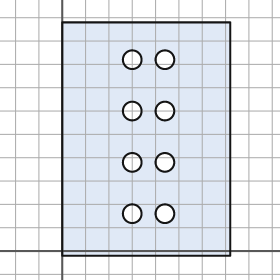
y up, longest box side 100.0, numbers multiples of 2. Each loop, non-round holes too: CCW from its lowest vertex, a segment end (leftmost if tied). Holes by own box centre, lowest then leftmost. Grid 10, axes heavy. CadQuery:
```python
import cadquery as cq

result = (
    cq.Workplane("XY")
    .moveTo(0.0, -2.0)
    .lineTo(72.0, -2.0)
    .lineTo(72.0, 98.0)
    .lineTo(0.0, 98.0)
    .close()
    .moveTo(30.0, 16.0)
    .circle(4.0)
    .moveTo(44.0, 16.0)
    .circle(4.0)
    .moveTo(30.0, 38.0)
    .circle(4.0)
    .moveTo(44.0, 38.0)
    .circle(4.0)
    .moveTo(30.0, 60.0)
    .circle(4.0)
    .moveTo(44.0, 60.0)
    .circle(4.0)
    .moveTo(30.0, 82.0)
    .circle(4.0)
    .moveTo(44.0, 82.0)
    .circle(4.0)
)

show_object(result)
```